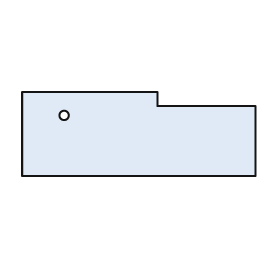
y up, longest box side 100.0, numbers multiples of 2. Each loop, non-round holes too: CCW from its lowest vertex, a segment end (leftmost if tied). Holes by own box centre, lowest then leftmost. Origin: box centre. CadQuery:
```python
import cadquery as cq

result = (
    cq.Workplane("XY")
    .moveTo(-50.0, -18.0)
    .lineTo(50.0, -18.0)
    .lineTo(50.0, 12.0)
    .lineTo(8.0, 12.0)
    .lineTo(8.0, 18.0)
    .lineTo(-50.0, 18.0)
    .close()
    .moveTo(-32.0, 8.0)
    .circle(2.0)
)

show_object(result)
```